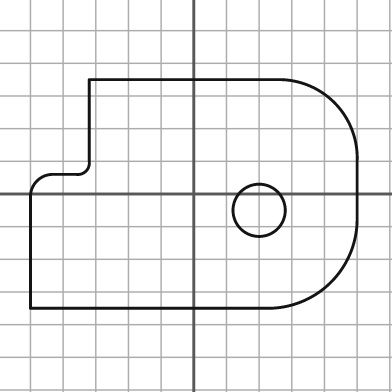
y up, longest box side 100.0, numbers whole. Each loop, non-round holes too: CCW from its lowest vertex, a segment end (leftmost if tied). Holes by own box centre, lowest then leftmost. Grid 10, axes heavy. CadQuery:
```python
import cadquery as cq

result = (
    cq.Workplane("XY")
    .moveTo(-50.0, -35.0)
    .lineTo(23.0, -35.0)
    .threePointArc((42.0, -27.0), (50.0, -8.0))
    .lineTo(50.0, 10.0)
    .threePointArc((43.0, 28.0), (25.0, 35.0))
    .lineTo(-32.0, 35.0)
    .lineTo(-32.0, 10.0)
    .threePointArc((-33.0, 7.0), (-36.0, 6.0))
    .lineTo(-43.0, 6.0)
    .threePointArc((-48.0, 4.0), (-50.0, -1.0))
    .close()
    .moveTo(20.0, -5.0)
    .circle(8.0)
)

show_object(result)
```